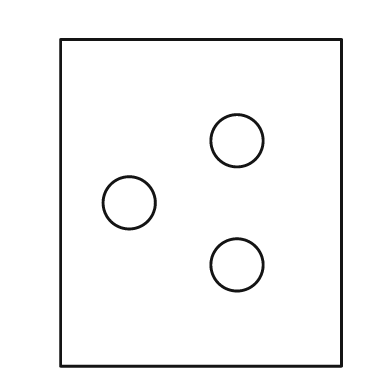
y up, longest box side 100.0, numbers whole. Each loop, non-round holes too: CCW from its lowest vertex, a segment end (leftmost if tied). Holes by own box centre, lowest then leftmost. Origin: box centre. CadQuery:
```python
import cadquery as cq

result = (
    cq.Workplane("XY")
    .moveTo(-43.0, -50.0)
    .lineTo(43.0, -50.0)
    .lineTo(43.0, 50.0)
    .lineTo(-43.0, 50.0)
    .close()
    .moveTo(11.0, -19.0)
    .circle(8.0)
    .moveTo(-22.0, 0.0)
    .circle(8.0)
    .moveTo(11.0, 19.0)
    .circle(8.0)
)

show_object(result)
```